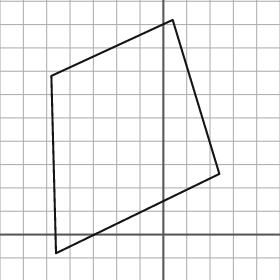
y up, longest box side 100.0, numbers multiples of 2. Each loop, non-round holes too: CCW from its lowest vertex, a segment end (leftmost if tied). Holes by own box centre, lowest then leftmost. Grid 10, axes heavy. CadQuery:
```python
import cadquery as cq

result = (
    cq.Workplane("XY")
    .moveTo(-46.0, -8.0)
    .lineTo(24.0, 26.0)
    .lineTo(4.0, 92.0)
    .lineTo(-48.0, 68.0)
    .close()
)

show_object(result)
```